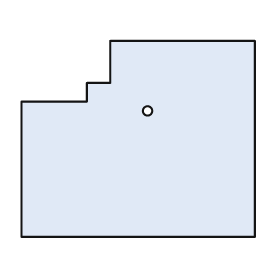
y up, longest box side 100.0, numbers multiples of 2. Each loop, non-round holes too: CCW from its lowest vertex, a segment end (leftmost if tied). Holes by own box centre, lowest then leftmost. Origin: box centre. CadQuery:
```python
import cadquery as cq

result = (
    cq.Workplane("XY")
    .moveTo(-50.0, -42.0)
    .lineTo(50.0, -42.0)
    .lineTo(50.0, 42.0)
    .lineTo(-12.0, 42.0)
    .lineTo(-12.0, 24.0)
    .lineTo(-22.0, 24.0)
    .lineTo(-22.0, 16.0)
    .lineTo(-50.0, 16.0)
    .close()
    .moveTo(4.0, 12.0)
    .circle(2.0)
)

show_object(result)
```